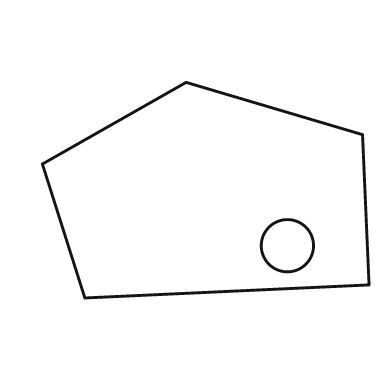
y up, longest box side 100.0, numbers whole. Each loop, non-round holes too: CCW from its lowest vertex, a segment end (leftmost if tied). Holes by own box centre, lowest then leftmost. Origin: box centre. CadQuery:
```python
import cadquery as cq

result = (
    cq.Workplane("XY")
    .moveTo(-37.0, -33.0)
    .lineTo(50.0, -29.0)
    .lineTo(48.0, 17.0)
    .lineTo(-6.0, 33.0)
    .lineTo(-50.0, 8.0)
    .close()
    .moveTo(25.0, -17.0)
    .circle(8.0)
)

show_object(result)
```